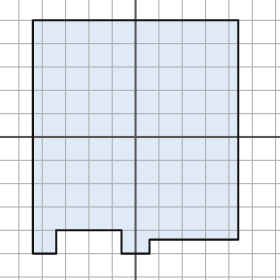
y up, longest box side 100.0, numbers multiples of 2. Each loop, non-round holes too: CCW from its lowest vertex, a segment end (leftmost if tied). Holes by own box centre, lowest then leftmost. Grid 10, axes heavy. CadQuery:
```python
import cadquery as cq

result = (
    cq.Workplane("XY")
    .moveTo(-44.0, -50.0)
    .lineTo(-34.0, -50.0)
    .lineTo(-34.0, -40.0)
    .lineTo(-6.0, -40.0)
    .lineTo(-6.0, -50.0)
    .lineTo(6.0, -50.0)
    .lineTo(6.0, -44.0)
    .lineTo(44.0, -44.0)
    .lineTo(44.0, 50.0)
    .lineTo(-44.0, 50.0)
    .close()
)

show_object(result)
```